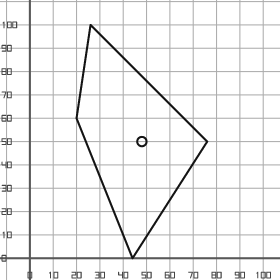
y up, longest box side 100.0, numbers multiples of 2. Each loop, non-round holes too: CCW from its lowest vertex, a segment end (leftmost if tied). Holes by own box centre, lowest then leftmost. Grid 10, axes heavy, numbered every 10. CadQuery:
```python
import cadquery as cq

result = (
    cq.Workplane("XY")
    .moveTo(44.0, 0.0)
    .lineTo(76.0, 50.0)
    .lineTo(26.0, 100.0)
    .lineTo(20.0, 60.0)
    .close()
    .moveTo(48.0, 50.0)
    .circle(2.0)
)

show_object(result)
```